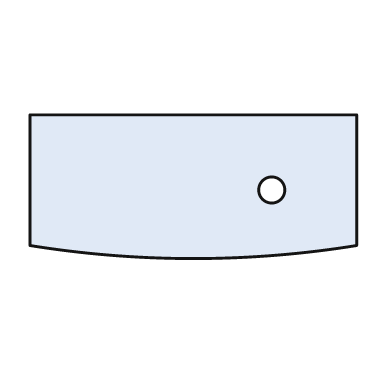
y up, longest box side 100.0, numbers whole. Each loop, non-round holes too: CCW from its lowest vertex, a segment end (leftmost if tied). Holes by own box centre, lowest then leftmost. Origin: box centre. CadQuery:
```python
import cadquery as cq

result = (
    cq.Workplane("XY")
    .moveTo(-50.0, -18.0)
    .threePointArc((0.0, -22.0), (50.0, -18.0))
    .lineTo(50.0, 22.0)
    .lineTo(-50.0, 22.0)
    .close()
    .moveTo(24.0, -1.0)
    .circle(4.0)
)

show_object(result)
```